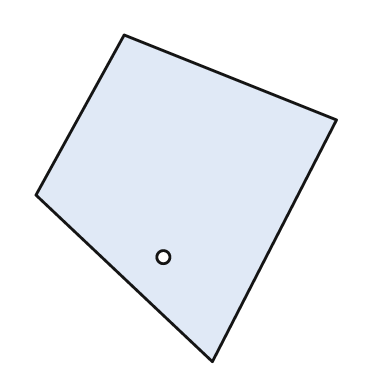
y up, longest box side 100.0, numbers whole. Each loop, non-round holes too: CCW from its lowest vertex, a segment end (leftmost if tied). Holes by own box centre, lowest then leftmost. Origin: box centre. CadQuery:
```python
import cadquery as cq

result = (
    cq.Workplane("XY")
    .moveTo(8.0, -50.0)
    .lineTo(46.0, 24.0)
    .lineTo(-19.0, 50.0)
    .lineTo(-46.0, 1.0)
    .close()
    .moveTo(-7.0, -18.0)
    .circle(2.0)
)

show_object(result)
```